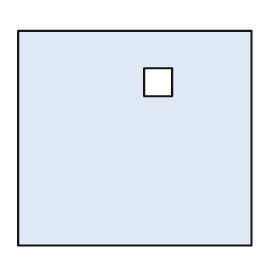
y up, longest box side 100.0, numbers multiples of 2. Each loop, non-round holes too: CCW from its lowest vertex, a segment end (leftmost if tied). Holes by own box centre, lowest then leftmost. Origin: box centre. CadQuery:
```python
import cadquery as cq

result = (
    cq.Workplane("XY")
    .moveTo(-50.0, -46.0)
    .lineTo(50.0, -46.0)
    .lineTo(50.0, 46.0)
    .lineTo(-50.0, 46.0)
    .close()
    .moveTo(4.0, 18.0)
    .lineTo(16.0, 18.0)
    .lineTo(16.0, 30.0)
    .lineTo(4.0, 30.0)
    .close()
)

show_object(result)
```